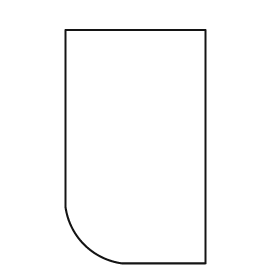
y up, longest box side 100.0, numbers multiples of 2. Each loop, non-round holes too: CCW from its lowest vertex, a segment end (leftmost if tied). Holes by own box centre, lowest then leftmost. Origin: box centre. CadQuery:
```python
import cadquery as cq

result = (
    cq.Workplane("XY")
    .moveTo(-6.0, -50.0)
    .lineTo(30.0, -50.0)
    .lineTo(30.0, 50.0)
    .lineTo(-30.0, 50.0)
    .lineTo(-30.0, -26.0)
    .threePointArc((-22.0, -42.0), (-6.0, -50.0))
    .close()
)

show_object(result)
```